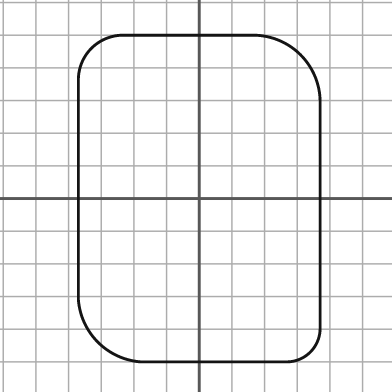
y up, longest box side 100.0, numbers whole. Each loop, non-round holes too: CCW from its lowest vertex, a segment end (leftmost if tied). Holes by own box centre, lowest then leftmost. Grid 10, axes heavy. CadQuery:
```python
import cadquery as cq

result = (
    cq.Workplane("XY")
    .moveTo(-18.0, -50.0)
    .lineTo(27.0, -50.0)
    .threePointArc((34.0, -47.0), (37.0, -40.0))
    .lineTo(37.0, 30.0)
    .threePointArc((31.0, 44.0), (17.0, 50.0))
    .lineTo(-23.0, 50.0)
    .threePointArc((-33.0, 46.0), (-37.0, 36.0))
    .lineTo(-37.0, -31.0)
    .threePointArc((-31.0, -44.0), (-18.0, -50.0))
    .close()
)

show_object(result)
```